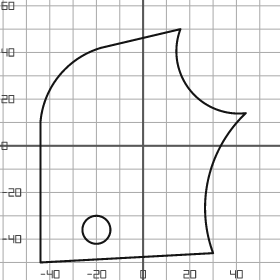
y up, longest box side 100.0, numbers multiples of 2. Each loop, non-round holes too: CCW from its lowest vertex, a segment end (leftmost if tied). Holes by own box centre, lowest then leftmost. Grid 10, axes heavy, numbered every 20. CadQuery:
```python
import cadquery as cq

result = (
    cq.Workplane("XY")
    .moveTo(-44.0, -50.0)
    .lineTo(30.0, -46.0)
    .threePointArc((28.0, -14.0), (44.0, 14.0))
    .threePointArc((20.0, 24.0), (16.0, 50.0))
    .lineTo(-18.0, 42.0)
    .threePointArc((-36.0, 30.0), (-44.0, 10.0))
    .close()
    .moveTo(-20.0, -36.0)
    .circle(6.0)
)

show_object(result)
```